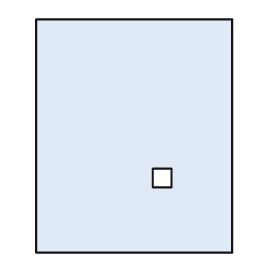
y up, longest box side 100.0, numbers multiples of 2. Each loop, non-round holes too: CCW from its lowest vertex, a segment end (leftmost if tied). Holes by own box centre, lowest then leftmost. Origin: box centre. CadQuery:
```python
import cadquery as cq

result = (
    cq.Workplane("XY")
    .moveTo(-42.0, -50.0)
    .lineTo(42.0, -50.0)
    .lineTo(42.0, 50.0)
    .lineTo(-42.0, 50.0)
    .close()
    .moveTo(8.0, -22.0)
    .lineTo(16.0, -22.0)
    .lineTo(16.0, -14.0)
    .lineTo(8.0, -14.0)
    .close()
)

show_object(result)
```